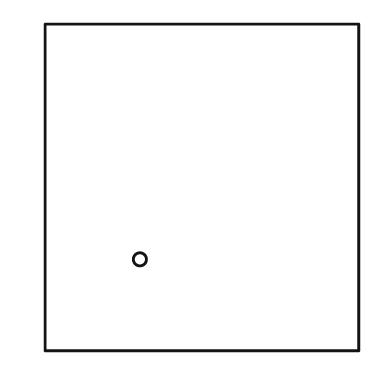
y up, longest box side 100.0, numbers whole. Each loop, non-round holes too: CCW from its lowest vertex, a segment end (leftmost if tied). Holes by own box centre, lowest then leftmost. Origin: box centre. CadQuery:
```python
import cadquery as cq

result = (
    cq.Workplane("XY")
    .moveTo(-48.0, -50.0)
    .lineTo(48.0, -50.0)
    .lineTo(48.0, 50.0)
    .lineTo(-48.0, 50.0)
    .close()
    .moveTo(-19.0, -22.0)
    .circle(2.0)
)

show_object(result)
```